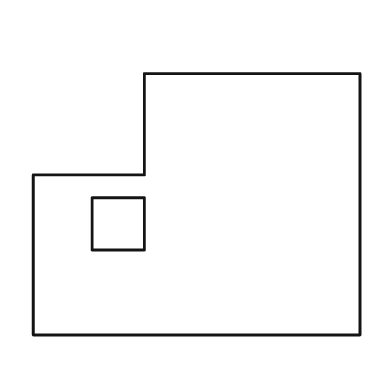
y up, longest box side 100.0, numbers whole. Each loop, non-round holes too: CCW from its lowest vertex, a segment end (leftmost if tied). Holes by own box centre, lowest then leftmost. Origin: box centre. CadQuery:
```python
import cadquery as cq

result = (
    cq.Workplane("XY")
    .moveTo(-50.0, -40.0)
    .lineTo(50.0, -40.0)
    .lineTo(50.0, 40.0)
    .lineTo(-16.0, 40.0)
    .lineTo(-16.0, 9.0)
    .lineTo(-50.0, 9.0)
    .close()
    .moveTo(-32.0, -14.0)
    .lineTo(-16.0, -14.0)
    .lineTo(-16.0, 2.0)
    .lineTo(-32.0, 2.0)
    .close()
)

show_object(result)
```